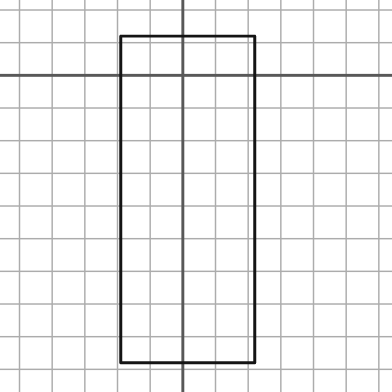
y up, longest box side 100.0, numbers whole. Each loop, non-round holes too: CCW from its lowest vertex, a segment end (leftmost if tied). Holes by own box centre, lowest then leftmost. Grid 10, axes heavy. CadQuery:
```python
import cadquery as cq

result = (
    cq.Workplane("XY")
    .moveTo(-19.0, -88.0)
    .lineTo(22.0, -88.0)
    .lineTo(22.0, 12.0)
    .lineTo(-19.0, 12.0)
    .close()
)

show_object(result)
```